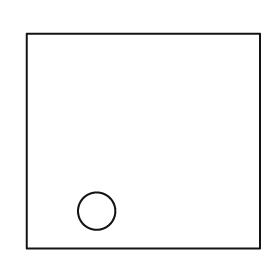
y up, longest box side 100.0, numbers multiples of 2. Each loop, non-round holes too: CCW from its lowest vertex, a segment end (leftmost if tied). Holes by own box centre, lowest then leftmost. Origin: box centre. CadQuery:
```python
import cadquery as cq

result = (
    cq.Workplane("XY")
    .moveTo(-50.0, -46.0)
    .lineTo(50.0, -46.0)
    .lineTo(50.0, 46.0)
    .lineTo(-50.0, 46.0)
    .close()
    .moveTo(-20.0, -30.0)
    .circle(8.0)
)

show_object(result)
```